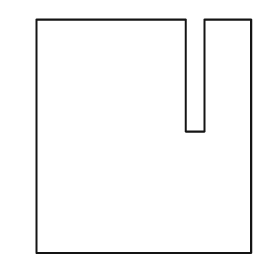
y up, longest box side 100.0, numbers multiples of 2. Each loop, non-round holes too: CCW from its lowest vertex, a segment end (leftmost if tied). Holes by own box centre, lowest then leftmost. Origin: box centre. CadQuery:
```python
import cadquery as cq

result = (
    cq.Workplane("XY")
    .moveTo(-46.0, -50.0)
    .lineTo(46.0, -50.0)
    .lineTo(46.0, 50.0)
    .lineTo(26.0, 50.0)
    .lineTo(26.0, 2.0)
    .lineTo(18.0, 2.0)
    .lineTo(18.0, 50.0)
    .lineTo(-46.0, 50.0)
    .close()
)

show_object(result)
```